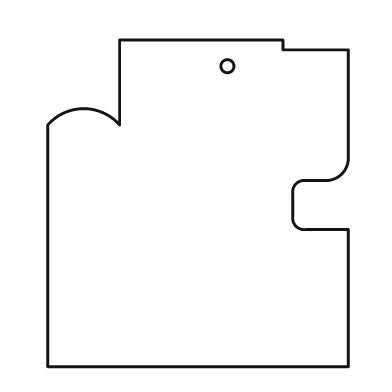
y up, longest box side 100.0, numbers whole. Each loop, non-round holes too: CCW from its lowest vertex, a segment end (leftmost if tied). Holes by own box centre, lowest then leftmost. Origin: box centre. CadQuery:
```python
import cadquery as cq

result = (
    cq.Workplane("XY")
    .moveTo(-46.0, -50.0)
    .lineTo(46.0, -50.0)
    .lineTo(46.0, -8.0)
    .lineTo(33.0, -8.0)
    .threePointArc((30.0, -7.0), (29.0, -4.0))
    .lineTo(29.0, 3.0)
    .threePointArc((30.0, 6.0), (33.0, 7.0))
    .lineTo(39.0, 7.0)
    .threePointArc((44.0, 9.0), (46.0, 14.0))
    .lineTo(46.0, 47.0)
    .lineTo(26.0, 47.0)
    .lineTo(26.0, 50.0)
    .lineTo(-24.0, 50.0)
    .lineTo(-24.0, 24.0)
    .threePointArc((-35.0, 29.0), (-46.0, 24.0))
    .close()
    .moveTo(9.0, 42.0)
    .circle(2.0)
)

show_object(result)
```